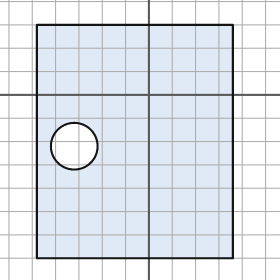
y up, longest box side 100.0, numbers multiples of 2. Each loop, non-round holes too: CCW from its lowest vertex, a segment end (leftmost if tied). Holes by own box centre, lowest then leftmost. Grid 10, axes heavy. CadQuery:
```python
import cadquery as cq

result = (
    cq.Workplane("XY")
    .moveTo(-48.0, -70.0)
    .lineTo(36.0, -70.0)
    .lineTo(36.0, 30.0)
    .lineTo(-48.0, 30.0)
    .close()
    .moveTo(-32.0, -22.0)
    .circle(10.0)
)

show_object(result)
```